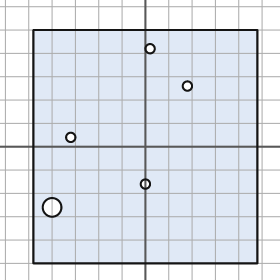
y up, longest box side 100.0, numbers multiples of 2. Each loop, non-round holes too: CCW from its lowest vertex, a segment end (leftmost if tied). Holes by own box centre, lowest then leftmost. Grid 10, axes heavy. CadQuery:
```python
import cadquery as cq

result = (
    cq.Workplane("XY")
    .moveTo(-48.0, -50.0)
    .lineTo(48.0, -50.0)
    .lineTo(48.0, 50.0)
    .lineTo(-48.0, 50.0)
    .close()
    .moveTo(-40.0, -26.0)
    .circle(4.0)
    .moveTo(0.0, -16.0)
    .circle(2.0)
    .moveTo(-32.0, 4.0)
    .circle(2.0)
    .moveTo(18.0, 26.0)
    .circle(2.0)
    .moveTo(2.0, 42.0)
    .circle(2.0)
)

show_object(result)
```